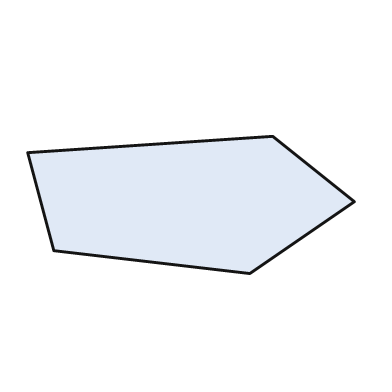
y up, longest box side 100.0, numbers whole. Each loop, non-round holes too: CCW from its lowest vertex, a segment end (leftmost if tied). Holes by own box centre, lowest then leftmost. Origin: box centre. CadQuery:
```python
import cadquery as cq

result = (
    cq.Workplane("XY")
    .moveTo(18.0, -21.0)
    .lineTo(50.0, 1.0)
    .lineTo(25.0, 21.0)
    .lineTo(-50.0, 16.0)
    .lineTo(-42.0, -14.0)
    .close()
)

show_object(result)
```